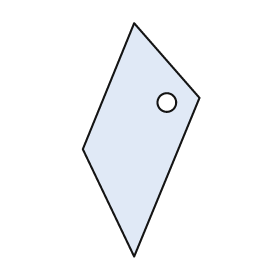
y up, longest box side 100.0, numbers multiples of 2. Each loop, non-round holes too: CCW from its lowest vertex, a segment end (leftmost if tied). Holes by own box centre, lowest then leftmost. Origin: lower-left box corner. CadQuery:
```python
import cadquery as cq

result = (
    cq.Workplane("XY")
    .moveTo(22.0, 0.0)
    .lineTo(50.0, 68.0)
    .lineTo(22.0, 100.0)
    .lineTo(0.0, 46.0)
    .close()
    .moveTo(36.0, 66.0)
    .circle(4.0)
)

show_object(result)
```